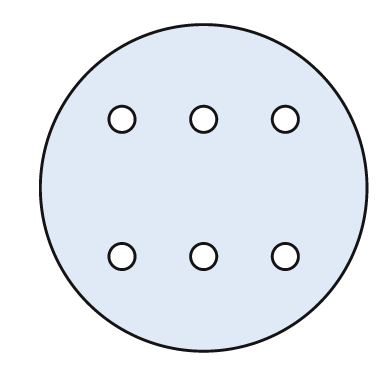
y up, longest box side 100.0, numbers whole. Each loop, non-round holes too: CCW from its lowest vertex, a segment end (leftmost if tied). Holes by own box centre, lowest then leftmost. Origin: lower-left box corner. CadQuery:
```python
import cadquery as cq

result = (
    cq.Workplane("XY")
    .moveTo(50.0, 50.0)
    .circle(50.0)
    .moveTo(25.0, 29.0)
    .circle(4.0)
    .moveTo(50.0, 29.0)
    .circle(4.0)
    .moveTo(75.0, 29.0)
    .circle(4.0)
    .moveTo(25.0, 71.0)
    .circle(4.0)
    .moveTo(50.0, 71.0)
    .circle(4.0)
    .moveTo(75.0, 71.0)
    .circle(4.0)
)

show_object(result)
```